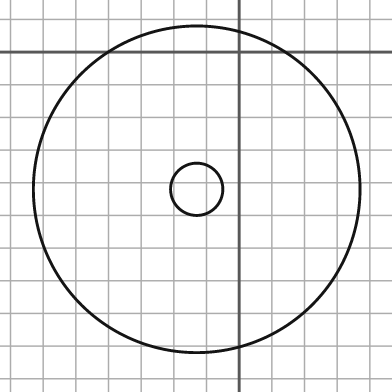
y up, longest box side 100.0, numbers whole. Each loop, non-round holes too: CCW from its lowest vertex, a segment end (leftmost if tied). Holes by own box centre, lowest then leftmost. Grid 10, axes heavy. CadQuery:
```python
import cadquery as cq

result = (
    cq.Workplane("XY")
    .moveTo(-13.0, -42.0)
    .circle(50.0)
    .moveTo(-13.0, -42.0)
    .circle(8.0)
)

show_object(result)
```